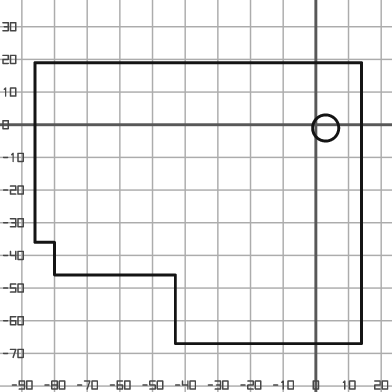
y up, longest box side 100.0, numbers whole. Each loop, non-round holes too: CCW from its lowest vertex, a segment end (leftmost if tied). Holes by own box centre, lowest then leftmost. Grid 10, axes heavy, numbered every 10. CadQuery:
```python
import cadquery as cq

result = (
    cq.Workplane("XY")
    .moveTo(-43.0, -67.0)
    .lineTo(14.0, -67.0)
    .lineTo(14.0, 19.0)
    .lineTo(-86.0, 19.0)
    .lineTo(-86.0, -36.0)
    .lineTo(-80.0, -36.0)
    .lineTo(-80.0, -46.0)
    .lineTo(-43.0, -46.0)
    .close()
    .moveTo(3.0, -1.0)
    .circle(4.0)
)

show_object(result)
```